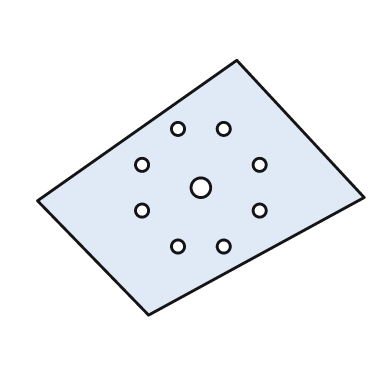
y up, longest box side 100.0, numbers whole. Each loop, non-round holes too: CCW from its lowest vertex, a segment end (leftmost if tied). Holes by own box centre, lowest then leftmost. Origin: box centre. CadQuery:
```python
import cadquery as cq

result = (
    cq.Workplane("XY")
    .moveTo(-16.0, -39.0)
    .lineTo(50.0, -3.0)
    .lineTo(11.0, 39.0)
    .lineTo(-50.0, -4.0)
    .close()
    .moveTo(-7.0, -18.0)
    .circle(2.0)
    .moveTo(7.0, -18.0)
    .circle(2.0)
    .moveTo(-18.0, -7.0)
    .circle(2.0)
    .moveTo(18.0, -7.0)
    .circle(2.0)
    .moveTo(0.0, 0.0)
    .circle(3.0)
    .moveTo(-18.0, 7.0)
    .circle(2.0)
    .moveTo(18.0, 7.0)
    .circle(2.0)
    .moveTo(-7.0, 18.0)
    .circle(2.0)
    .moveTo(7.0, 18.0)
    .circle(2.0)
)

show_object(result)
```